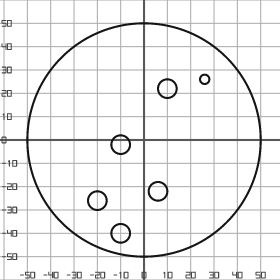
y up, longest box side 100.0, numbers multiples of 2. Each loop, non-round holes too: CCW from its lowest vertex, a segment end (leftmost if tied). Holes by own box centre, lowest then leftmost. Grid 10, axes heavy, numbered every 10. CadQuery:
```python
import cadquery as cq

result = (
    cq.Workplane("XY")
    .moveTo(0.0, 0.0)
    .circle(50.0)
    .moveTo(-10.0, -40.0)
    .circle(4.0)
    .moveTo(-20.0, -26.0)
    .circle(4.0)
    .moveTo(6.0, -22.0)
    .circle(4.0)
    .moveTo(-10.0, -2.0)
    .circle(4.0)
    .moveTo(10.0, 22.0)
    .circle(4.0)
    .moveTo(26.0, 26.0)
    .circle(2.0)
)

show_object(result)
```